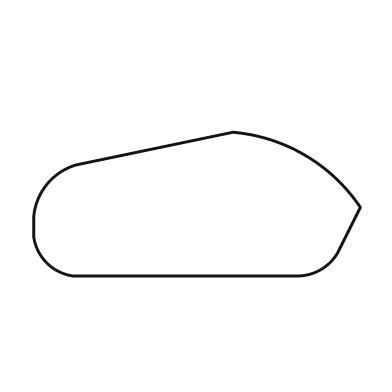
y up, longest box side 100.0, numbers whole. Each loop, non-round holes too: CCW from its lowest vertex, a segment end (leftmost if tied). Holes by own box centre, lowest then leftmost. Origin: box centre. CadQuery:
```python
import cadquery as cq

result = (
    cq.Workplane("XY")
    .moveTo(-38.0, -22.0)
    .lineTo(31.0, -22.0)
    .threePointArc((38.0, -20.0), (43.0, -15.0))
    .lineTo(50.0, -1.0)
    .threePointArc((33.0, 15.0), (11.0, 22.0))
    .lineTo(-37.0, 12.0)
    .threePointArc((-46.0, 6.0), (-50.0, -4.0))
    .lineTo(-50.0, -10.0)
    .threePointArc((-46.0, -18.0), (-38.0, -22.0))
    .close()
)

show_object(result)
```